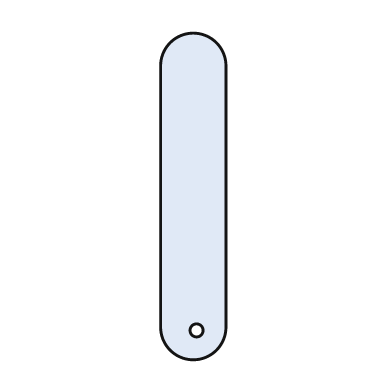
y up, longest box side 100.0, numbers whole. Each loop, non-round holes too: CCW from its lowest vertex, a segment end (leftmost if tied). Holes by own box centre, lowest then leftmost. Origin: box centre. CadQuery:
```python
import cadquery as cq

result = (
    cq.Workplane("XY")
    .moveTo(-10.0, -40.0)
    .threePointArc((0.0, -50.0), (10.0, -40.0))
    .lineTo(10.0, 40.0)
    .threePointArc((0.0, 50.0), (-10.0, 40.0))
    .close()
    .moveTo(1.0, -41.0)
    .circle(2.0)
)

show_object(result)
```